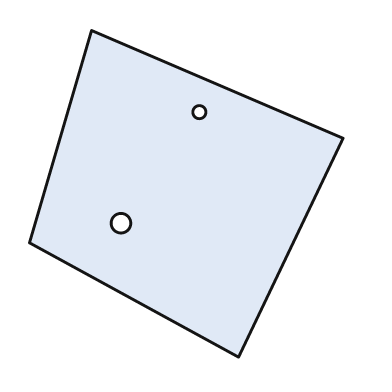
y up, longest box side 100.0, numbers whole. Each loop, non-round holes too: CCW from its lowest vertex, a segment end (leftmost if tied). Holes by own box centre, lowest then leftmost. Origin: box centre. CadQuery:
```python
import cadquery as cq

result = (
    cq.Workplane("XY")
    .moveTo(16.0, -50.0)
    .lineTo(48.0, 17.0)
    .lineTo(-29.0, 50.0)
    .lineTo(-48.0, -15.0)
    .close()
    .moveTo(-20.0, -9.0)
    .circle(3.0)
    .moveTo(4.0, 25.0)
    .circle(2.0)
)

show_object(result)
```